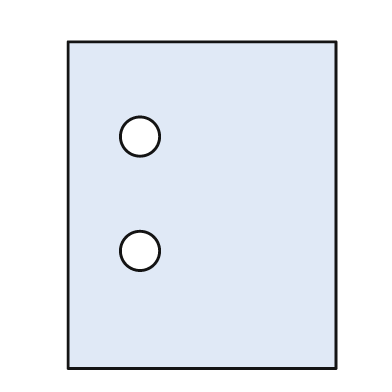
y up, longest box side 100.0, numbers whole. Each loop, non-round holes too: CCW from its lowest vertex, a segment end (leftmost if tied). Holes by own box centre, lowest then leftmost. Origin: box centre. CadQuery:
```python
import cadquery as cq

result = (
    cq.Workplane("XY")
    .moveTo(-41.0, -50.0)
    .lineTo(41.0, -50.0)
    .lineTo(41.0, 50.0)
    .lineTo(-41.0, 50.0)
    .close()
    .moveTo(-19.0, -14.0)
    .circle(6.0)
    .moveTo(-19.0, 21.0)
    .circle(6.0)
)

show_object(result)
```